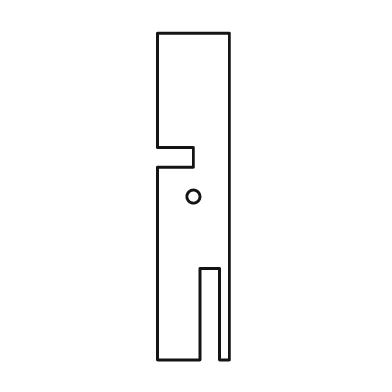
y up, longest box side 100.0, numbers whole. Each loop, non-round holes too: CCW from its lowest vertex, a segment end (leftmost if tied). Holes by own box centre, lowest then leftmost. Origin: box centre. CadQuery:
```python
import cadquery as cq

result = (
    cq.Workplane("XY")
    .moveTo(-11.0, -50.0)
    .lineTo(2.0, -50.0)
    .lineTo(2.0, -22.0)
    .lineTo(8.0, -22.0)
    .lineTo(8.0, -50.0)
    .lineTo(11.0, -50.0)
    .lineTo(11.0, 50.0)
    .lineTo(-11.0, 50.0)
    .lineTo(-11.0, 15.0)
    .lineTo(0.0, 15.0)
    .lineTo(0.0, 9.0)
    .lineTo(-11.0, 9.0)
    .close()
    .moveTo(0.0, 0.0)
    .circle(2.0)
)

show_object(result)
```